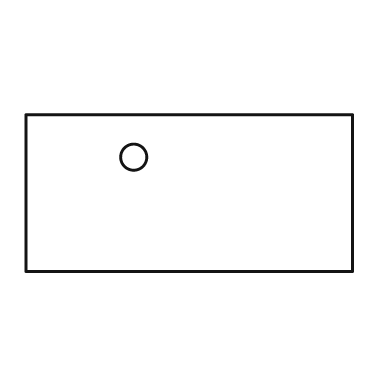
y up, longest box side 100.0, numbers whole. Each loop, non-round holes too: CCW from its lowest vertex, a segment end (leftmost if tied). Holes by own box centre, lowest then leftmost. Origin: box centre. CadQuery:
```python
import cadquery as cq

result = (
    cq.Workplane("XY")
    .moveTo(-50.0, -24.0)
    .lineTo(50.0, -24.0)
    .lineTo(50.0, 24.0)
    .lineTo(-50.0, 24.0)
    .close()
    .moveTo(-17.0, 11.0)
    .circle(4.0)
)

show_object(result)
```